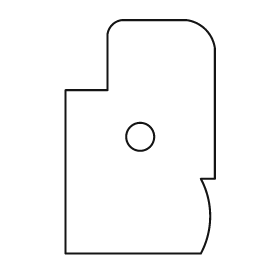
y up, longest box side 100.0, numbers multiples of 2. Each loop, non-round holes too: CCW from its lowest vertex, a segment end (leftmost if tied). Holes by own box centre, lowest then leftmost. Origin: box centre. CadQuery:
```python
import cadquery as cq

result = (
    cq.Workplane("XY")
    .moveTo(-32.0, -50.0)
    .lineTo(26.0, -50.0)
    .threePointArc((30.0, -34.0), (26.0, -18.0))
    .lineTo(32.0, -18.0)
    .lineTo(32.0, 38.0)
    .threePointArc((28.0, 46.0), (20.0, 50.0))
    .lineTo(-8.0, 50.0)
    .threePointArc((-12.0, 48.0), (-14.0, 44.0))
    .lineTo(-14.0, 20.0)
    .lineTo(-32.0, 20.0)
    .close()
    .moveTo(0.0, 0.0)
    .circle(6.0)
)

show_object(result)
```